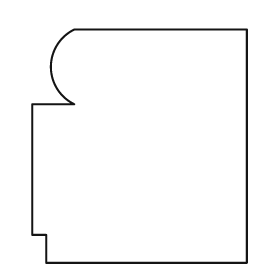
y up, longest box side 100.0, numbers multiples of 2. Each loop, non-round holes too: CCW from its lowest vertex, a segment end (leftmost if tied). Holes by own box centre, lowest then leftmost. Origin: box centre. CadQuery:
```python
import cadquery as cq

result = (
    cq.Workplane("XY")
    .moveTo(-40.0, -50.0)
    .lineTo(46.0, -50.0)
    .lineTo(46.0, 50.0)
    .lineTo(-28.0, 50.0)
    .threePointArc((-38.0, 34.0), (-28.0, 18.0))
    .lineTo(-46.0, 18.0)
    .lineTo(-46.0, -38.0)
    .lineTo(-40.0, -38.0)
    .close()
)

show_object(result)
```